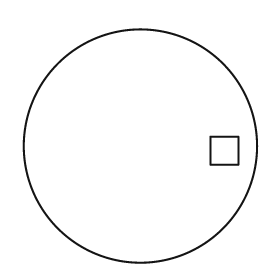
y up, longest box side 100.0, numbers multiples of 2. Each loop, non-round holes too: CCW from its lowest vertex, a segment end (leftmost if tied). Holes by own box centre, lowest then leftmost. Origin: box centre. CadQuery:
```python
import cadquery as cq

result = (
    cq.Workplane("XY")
    .moveTo(0.0, 0.0)
    .circle(50.0)
    .moveTo(30.0, -8.0)
    .lineTo(42.0, -8.0)
    .lineTo(42.0, 4.0)
    .lineTo(30.0, 4.0)
    .close()
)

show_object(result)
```